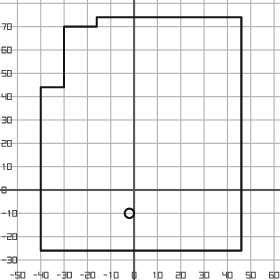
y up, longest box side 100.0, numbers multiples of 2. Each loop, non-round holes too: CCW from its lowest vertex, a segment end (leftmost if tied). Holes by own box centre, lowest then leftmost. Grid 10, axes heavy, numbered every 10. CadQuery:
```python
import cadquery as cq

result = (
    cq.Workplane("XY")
    .moveTo(-40.0, -26.0)
    .lineTo(46.0, -26.0)
    .lineTo(46.0, 74.0)
    .lineTo(-16.0, 74.0)
    .lineTo(-16.0, 70.0)
    .lineTo(-30.0, 70.0)
    .lineTo(-30.0, 44.0)
    .lineTo(-40.0, 44.0)
    .close()
    .moveTo(-2.0, -10.0)
    .circle(2.0)
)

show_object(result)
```